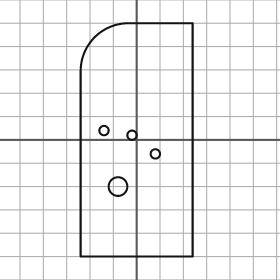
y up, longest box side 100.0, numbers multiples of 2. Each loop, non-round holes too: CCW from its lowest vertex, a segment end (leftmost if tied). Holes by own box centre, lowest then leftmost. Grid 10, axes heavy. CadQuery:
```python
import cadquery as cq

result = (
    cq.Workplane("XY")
    .moveTo(-24.0, -50.0)
    .lineTo(24.0, -50.0)
    .lineTo(24.0, 50.0)
    .lineTo(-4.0, 50.0)
    .threePointArc((-18.0, 44.0), (-24.0, 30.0))
    .close()
    .moveTo(-8.0, -20.0)
    .circle(4.0)
    .moveTo(8.0, -6.0)
    .circle(2.0)
    .moveTo(-2.0, 2.0)
    .circle(2.0)
    .moveTo(-14.0, 4.0)
    .circle(2.0)
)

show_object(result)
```